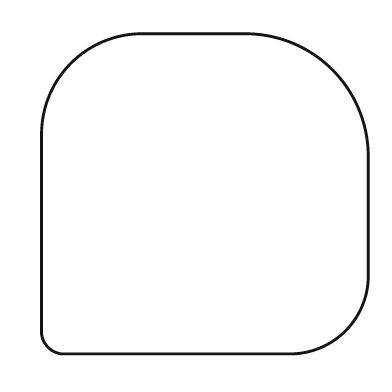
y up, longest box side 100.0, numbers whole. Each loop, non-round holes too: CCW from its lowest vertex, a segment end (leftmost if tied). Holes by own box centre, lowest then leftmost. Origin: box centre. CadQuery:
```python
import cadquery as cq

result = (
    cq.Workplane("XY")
    .moveTo(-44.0, -49.0)
    .lineTo(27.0, -49.0)
    .threePointArc((43.0, -42.0), (50.0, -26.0))
    .lineTo(50.0, 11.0)
    .threePointArc((39.0, 38.0), (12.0, 49.0))
    .lineTo(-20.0, 49.0)
    .threePointArc((-41.0, 40.0), (-50.0, 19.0))
    .lineTo(-50.0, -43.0)
    .threePointArc((-48.0, -47.0), (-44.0, -49.0))
    .close()
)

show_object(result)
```